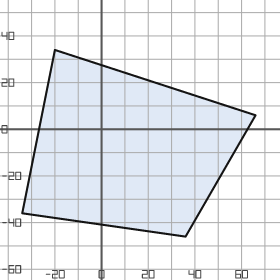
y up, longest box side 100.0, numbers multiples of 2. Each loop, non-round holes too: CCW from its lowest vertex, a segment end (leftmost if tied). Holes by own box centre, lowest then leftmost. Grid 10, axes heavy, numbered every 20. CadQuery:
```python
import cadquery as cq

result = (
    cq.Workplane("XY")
    .moveTo(36.0, -46.0)
    .lineTo(66.0, 6.0)
    .lineTo(-20.0, 34.0)
    .lineTo(-34.0, -36.0)
    .close()
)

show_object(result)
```